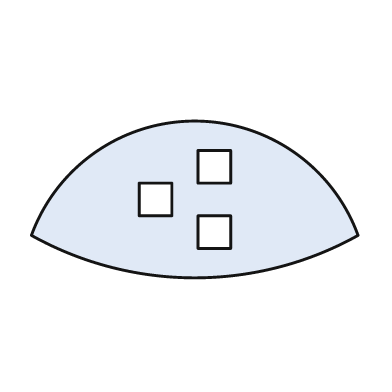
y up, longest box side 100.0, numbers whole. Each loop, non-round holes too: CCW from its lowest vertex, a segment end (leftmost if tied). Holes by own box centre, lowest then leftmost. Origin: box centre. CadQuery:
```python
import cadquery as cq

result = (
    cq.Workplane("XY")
    .moveTo(-50.0, -11.0)
    .threePointArc((0.0, -24.0), (50.0, -11.0))
    .threePointArc((0.0, 24.0), (-50.0, -11.0))
    .close()
    .moveTo(1.0, -15.0)
    .lineTo(11.0, -15.0)
    .lineTo(11.0, -5.0)
    .lineTo(1.0, -5.0)
    .close()
    .moveTo(-17.0, -5.0)
    .lineTo(-7.0, -5.0)
    .lineTo(-7.0, 5.0)
    .lineTo(-17.0, 5.0)
    .close()
    .moveTo(1.0, 5.0)
    .lineTo(11.0, 5.0)
    .lineTo(11.0, 15.0)
    .lineTo(1.0, 15.0)
    .close()
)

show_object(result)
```